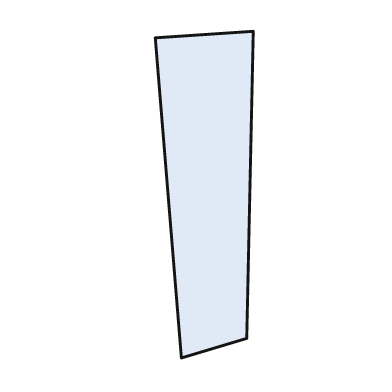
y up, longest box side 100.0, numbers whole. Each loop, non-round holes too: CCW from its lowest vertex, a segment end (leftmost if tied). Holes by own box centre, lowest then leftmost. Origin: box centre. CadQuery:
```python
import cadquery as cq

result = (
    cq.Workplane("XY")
    .moveTo(-7.0, -50.0)
    .lineTo(13.0, -44.0)
    .lineTo(15.0, 50.0)
    .lineTo(-15.0, 48.0)
    .close()
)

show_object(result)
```